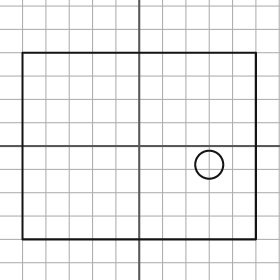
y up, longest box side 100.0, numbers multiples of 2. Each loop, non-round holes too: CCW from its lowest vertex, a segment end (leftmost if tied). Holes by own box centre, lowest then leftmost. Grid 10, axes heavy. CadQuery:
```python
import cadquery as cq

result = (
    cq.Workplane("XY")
    .moveTo(-50.0, -40.0)
    .lineTo(50.0, -40.0)
    .lineTo(50.0, 40.0)
    .lineTo(-50.0, 40.0)
    .close()
    .moveTo(30.0, -8.0)
    .circle(6.0)
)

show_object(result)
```